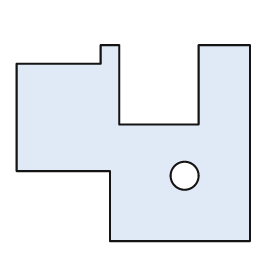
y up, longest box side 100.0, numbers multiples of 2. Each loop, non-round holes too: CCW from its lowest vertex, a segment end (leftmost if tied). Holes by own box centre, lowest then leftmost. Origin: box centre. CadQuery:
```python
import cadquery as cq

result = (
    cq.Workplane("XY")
    .moveTo(-10.0, -42.0)
    .lineTo(50.0, -42.0)
    .lineTo(50.0, 42.0)
    .lineTo(28.0, 42.0)
    .lineTo(28.0, 8.0)
    .lineTo(-6.0, 8.0)
    .lineTo(-6.0, 42.0)
    .lineTo(-14.0, 42.0)
    .lineTo(-14.0, 34.0)
    .lineTo(-50.0, 34.0)
    .lineTo(-50.0, -12.0)
    .lineTo(-10.0, -12.0)
    .close()
    .moveTo(22.0, -14.0)
    .circle(6.0)
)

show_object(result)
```